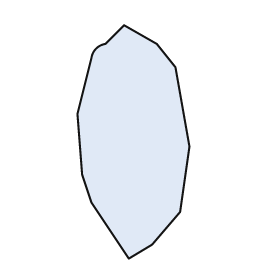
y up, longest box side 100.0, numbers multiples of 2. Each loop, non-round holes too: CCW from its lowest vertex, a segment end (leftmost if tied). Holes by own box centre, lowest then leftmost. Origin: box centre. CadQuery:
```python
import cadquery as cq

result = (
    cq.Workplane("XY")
    .moveTo(-2.0, -50.0)
    .lineTo(8.0, -44.0)
    .lineTo(20.0, -30.0)
    .lineTo(24.0, -2.0)
    .lineTo(18.0, 32.0)
    .lineTo(10.0, 42.0)
    .lineTo(-4.0, 50.0)
    .lineTo(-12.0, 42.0)
    .threePointArc((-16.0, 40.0), (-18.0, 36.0))
    .lineTo(-24.0, 12.0)
    .lineTo(-22.0, -14.0)
    .lineTo(-18.0, -26.0)
    .close()
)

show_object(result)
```